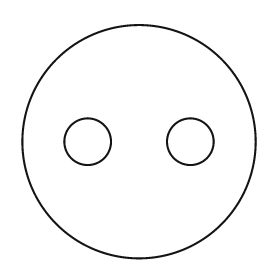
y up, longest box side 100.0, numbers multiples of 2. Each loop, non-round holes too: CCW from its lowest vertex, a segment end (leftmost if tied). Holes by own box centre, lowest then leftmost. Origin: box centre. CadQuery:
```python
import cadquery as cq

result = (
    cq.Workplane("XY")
    .moveTo(0.0, 0.0)
    .circle(50.0)
    .moveTo(-22.0, 0.0)
    .circle(10.0)
    .moveTo(22.0, 0.0)
    .circle(10.0)
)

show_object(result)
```